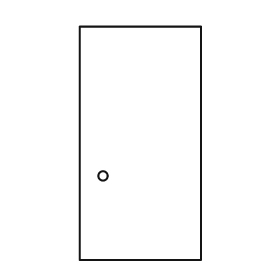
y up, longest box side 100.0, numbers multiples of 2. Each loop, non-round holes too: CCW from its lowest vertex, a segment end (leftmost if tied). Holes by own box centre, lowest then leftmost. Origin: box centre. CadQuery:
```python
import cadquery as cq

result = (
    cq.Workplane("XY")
    .moveTo(-26.0, -50.0)
    .lineTo(26.0, -50.0)
    .lineTo(26.0, 50.0)
    .lineTo(-26.0, 50.0)
    .close()
    .moveTo(-16.0, -14.0)
    .circle(2.0)
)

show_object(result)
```